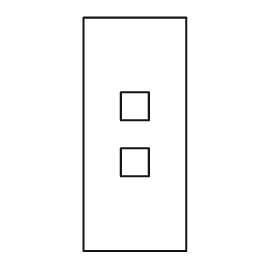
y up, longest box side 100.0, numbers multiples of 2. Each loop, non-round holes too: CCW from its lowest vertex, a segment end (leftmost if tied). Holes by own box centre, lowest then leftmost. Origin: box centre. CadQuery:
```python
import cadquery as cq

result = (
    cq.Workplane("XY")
    .moveTo(-22.0, -50.0)
    .lineTo(22.0, -50.0)
    .lineTo(22.0, 50.0)
    .lineTo(-22.0, 50.0)
    .close()
    .moveTo(-6.0, -18.0)
    .lineTo(6.0, -18.0)
    .lineTo(6.0, -6.0)
    .lineTo(-6.0, -6.0)
    .close()
    .moveTo(-6.0, 6.0)
    .lineTo(6.0, 6.0)
    .lineTo(6.0, 18.0)
    .lineTo(-6.0, 18.0)
    .close()
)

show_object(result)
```